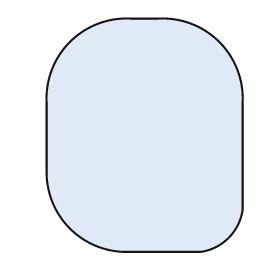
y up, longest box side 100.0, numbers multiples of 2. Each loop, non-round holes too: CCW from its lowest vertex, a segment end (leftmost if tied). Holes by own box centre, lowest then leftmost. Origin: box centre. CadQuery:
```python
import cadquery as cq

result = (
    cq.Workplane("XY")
    .moveTo(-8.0, -50.0)
    .lineTo(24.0, -50.0)
    .threePointArc((36.0, -44.0), (42.0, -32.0))
    .lineTo(42.0, 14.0)
    .threePointArc((32.0, 40.0), (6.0, 50.0))
    .lineTo(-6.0, 50.0)
    .threePointArc((-32.0, 40.0), (-42.0, 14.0))
    .lineTo(-42.0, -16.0)
    .threePointArc((-32.0, -40.0), (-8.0, -50.0))
    .close()
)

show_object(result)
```